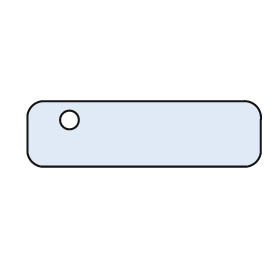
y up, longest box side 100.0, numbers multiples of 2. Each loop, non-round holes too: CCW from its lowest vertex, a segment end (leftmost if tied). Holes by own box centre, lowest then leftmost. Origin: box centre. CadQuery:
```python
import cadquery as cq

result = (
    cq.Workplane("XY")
    .moveTo(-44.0, -14.0)
    .lineTo(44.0, -14.0)
    .threePointArc((48.0, -12.0), (50.0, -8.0))
    .lineTo(50.0, 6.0)
    .threePointArc((48.0, 12.0), (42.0, 14.0))
    .lineTo(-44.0, 14.0)
    .threePointArc((-48.0, 12.0), (-50.0, 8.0))
    .lineTo(-50.0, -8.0)
    .threePointArc((-48.0, -12.0), (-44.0, -14.0))
    .close()
    .moveTo(-32.0, 6.0)
    .circle(4.0)
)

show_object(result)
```